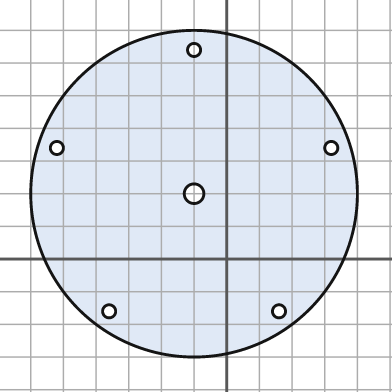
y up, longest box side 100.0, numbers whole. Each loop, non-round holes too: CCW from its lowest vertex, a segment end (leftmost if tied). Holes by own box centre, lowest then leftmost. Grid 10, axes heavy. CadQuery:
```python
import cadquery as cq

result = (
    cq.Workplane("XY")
    .moveTo(-10.0, 20.0)
    .circle(50.0)
    .moveTo(-36.0, -16.0)
    .circle(2.0)
    .moveTo(16.0, -16.0)
    .circle(2.0)
    .moveTo(-10.0, 20.0)
    .circle(3.0)
    .moveTo(-52.0, 34.0)
    .circle(2.0)
    .moveTo(32.0, 34.0)
    .circle(2.0)
    .moveTo(-10.0, 64.0)
    .circle(2.0)
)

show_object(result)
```